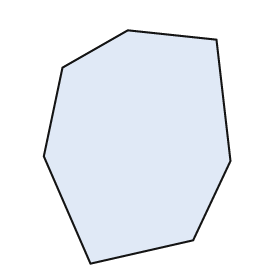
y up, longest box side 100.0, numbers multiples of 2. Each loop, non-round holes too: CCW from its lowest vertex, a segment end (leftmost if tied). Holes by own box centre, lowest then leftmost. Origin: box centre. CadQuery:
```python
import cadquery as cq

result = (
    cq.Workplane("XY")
    .moveTo(-20.0, -50.0)
    .lineTo(24.0, -40.0)
    .lineTo(40.0, -6.0)
    .lineTo(34.0, 46.0)
    .lineTo(-4.0, 50.0)
    .lineTo(-32.0, 34.0)
    .lineTo(-40.0, -4.0)
    .close()
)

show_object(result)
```